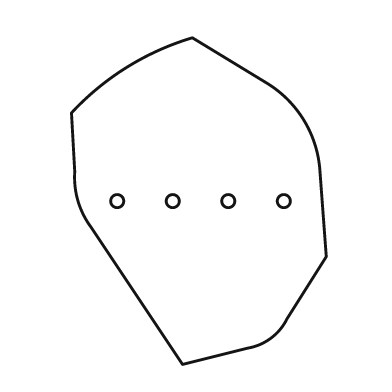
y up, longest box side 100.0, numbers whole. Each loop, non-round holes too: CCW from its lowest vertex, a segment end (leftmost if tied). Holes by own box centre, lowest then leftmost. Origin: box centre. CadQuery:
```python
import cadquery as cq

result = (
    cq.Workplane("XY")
    .moveTo(-5.0, -50.0)
    .lineTo(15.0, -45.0)
    .threePointArc((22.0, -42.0), (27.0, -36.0))
    .lineTo(39.0, -17.0)
    .lineTo(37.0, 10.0)
    .threePointArc((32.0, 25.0), (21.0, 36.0))
    .lineTo(-2.0, 50.0)
    .threePointArc((-22.0, 41.0), (-39.0, 27.0))
    .lineTo(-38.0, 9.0)
    .threePointArc((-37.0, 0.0), (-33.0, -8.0))
    .close()
    .moveTo(-25.0, 0.0)
    .circle(2.0)
    .moveTo(-8.0, 0.0)
    .circle(2.0)
    .moveTo(9.0, 0.0)
    .circle(2.0)
    .moveTo(26.0, 0.0)
    .circle(2.0)
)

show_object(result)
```